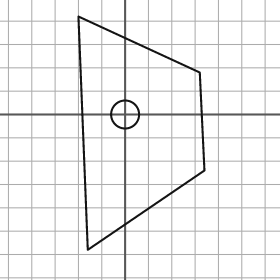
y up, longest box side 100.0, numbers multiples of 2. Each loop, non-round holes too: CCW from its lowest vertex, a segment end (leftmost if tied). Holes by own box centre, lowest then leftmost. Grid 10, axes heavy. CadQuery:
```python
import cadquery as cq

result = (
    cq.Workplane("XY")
    .moveTo(-16.0, -58.0)
    .lineTo(34.0, -24.0)
    .lineTo(32.0, 18.0)
    .lineTo(-20.0, 42.0)
    .close()
    .moveTo(0.0, 0.0)
    .circle(6.0)
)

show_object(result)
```